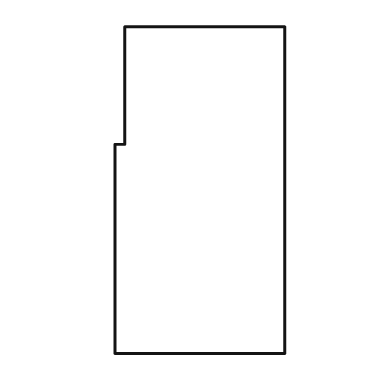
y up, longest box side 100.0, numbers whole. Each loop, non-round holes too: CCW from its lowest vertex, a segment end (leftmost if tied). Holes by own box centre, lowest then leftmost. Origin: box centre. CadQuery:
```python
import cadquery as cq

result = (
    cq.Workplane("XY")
    .moveTo(-26.0, -50.0)
    .lineTo(26.0, -50.0)
    .lineTo(26.0, 50.0)
    .lineTo(-23.0, 50.0)
    .lineTo(-23.0, 14.0)
    .lineTo(-26.0, 14.0)
    .close()
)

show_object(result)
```